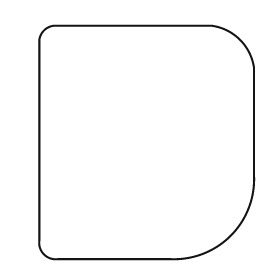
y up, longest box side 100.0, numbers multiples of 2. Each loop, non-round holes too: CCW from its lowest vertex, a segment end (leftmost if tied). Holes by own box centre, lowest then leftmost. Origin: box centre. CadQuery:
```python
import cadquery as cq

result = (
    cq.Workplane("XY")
    .moveTo(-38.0, -50.0)
    .lineTo(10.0, -50.0)
    .threePointArc((36.0, -40.0), (46.0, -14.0))
    .lineTo(46.0, 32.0)
    .threePointArc((40.0, 44.0), (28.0, 50.0))
    .lineTo(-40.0, 50.0)
    .threePointArc((-44.0, 48.0), (-46.0, 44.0))
    .lineTo(-46.0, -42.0)
    .threePointArc((-44.0, -48.0), (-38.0, -50.0))
    .close()
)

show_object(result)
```